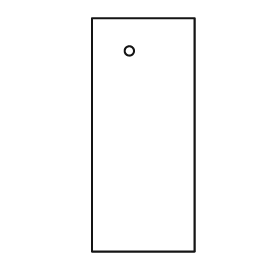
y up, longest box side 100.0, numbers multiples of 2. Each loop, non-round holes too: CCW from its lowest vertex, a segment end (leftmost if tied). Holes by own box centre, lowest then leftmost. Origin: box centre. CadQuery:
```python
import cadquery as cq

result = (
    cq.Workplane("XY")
    .moveTo(-22.0, -50.0)
    .lineTo(22.0, -50.0)
    .lineTo(22.0, 50.0)
    .lineTo(-22.0, 50.0)
    .close()
    .moveTo(-6.0, 36.0)
    .circle(2.0)
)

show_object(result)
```